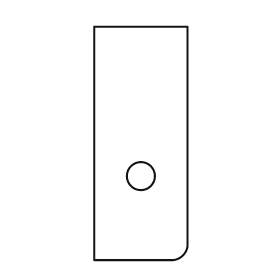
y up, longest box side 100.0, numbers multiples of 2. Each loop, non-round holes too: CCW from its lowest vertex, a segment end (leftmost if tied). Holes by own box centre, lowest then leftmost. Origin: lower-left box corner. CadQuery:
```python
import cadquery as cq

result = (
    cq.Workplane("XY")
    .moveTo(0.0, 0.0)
    .lineTo(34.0, 0.0)
    .threePointArc((38.0, 2.0), (40.0, 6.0))
    .lineTo(40.0, 100.0)
    .lineTo(0.0, 100.0)
    .close()
    .moveTo(20.0, 36.0)
    .circle(6.0)
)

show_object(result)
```